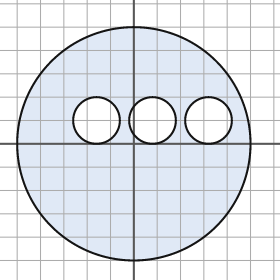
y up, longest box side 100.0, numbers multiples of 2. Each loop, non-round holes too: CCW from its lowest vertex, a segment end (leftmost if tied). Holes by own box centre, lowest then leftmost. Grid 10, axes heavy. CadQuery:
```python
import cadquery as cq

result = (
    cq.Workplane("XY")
    .moveTo(0.0, 0.0)
    .circle(50.0)
    .moveTo(-16.0, 10.0)
    .circle(10.0)
    .moveTo(8.0, 10.0)
    .circle(10.0)
    .moveTo(32.0, 10.0)
    .circle(10.0)
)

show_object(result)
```